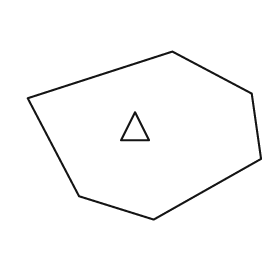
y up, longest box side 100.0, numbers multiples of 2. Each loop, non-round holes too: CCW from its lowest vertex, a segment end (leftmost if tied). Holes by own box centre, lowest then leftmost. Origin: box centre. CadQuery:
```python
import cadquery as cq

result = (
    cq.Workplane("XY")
    .moveTo(4.0, -36.0)
    .lineTo(50.0, -10.0)
    .lineTo(46.0, 18.0)
    .lineTo(12.0, 36.0)
    .lineTo(-50.0, 16.0)
    .lineTo(-28.0, -26.0)
    .close()
    .moveTo(-10.0, -2.0)
    .lineTo(2.0, -2.0)
    .lineTo(-4.0, 10.0)
    .close()
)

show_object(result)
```